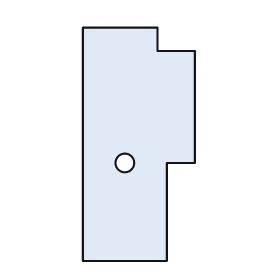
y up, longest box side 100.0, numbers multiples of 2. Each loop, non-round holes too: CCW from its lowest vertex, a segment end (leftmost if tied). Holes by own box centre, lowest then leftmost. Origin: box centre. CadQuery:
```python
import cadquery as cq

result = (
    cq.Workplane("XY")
    .moveTo(-24.0, -50.0)
    .lineTo(12.0, -50.0)
    .lineTo(12.0, -8.0)
    .lineTo(24.0, -8.0)
    .lineTo(24.0, 40.0)
    .lineTo(8.0, 40.0)
    .lineTo(8.0, 50.0)
    .lineTo(-24.0, 50.0)
    .close()
    .moveTo(-6.0, -8.0)
    .circle(4.0)
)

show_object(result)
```